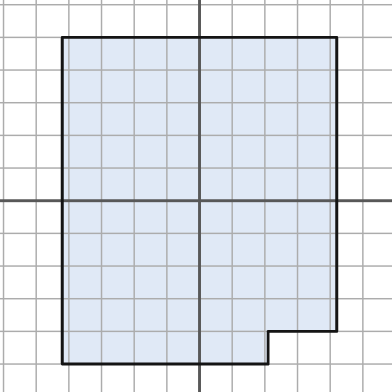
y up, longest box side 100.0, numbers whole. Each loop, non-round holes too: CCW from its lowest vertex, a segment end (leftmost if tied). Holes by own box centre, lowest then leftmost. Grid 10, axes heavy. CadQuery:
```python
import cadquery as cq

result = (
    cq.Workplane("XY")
    .moveTo(-42.0, -50.0)
    .lineTo(21.0, -50.0)
    .lineTo(21.0, -40.0)
    .lineTo(42.0, -40.0)
    .lineTo(42.0, 50.0)
    .lineTo(-42.0, 50.0)
    .close()
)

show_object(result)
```